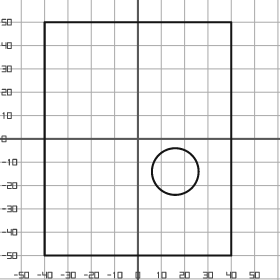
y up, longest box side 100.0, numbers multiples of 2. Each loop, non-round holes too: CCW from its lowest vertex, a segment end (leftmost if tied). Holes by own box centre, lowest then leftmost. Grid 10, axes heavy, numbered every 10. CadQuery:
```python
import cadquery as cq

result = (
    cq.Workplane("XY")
    .moveTo(-40.0, -50.0)
    .lineTo(40.0, -50.0)
    .lineTo(40.0, 50.0)
    .lineTo(-40.0, 50.0)
    .close()
    .moveTo(16.0, -14.0)
    .circle(10.0)
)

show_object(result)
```